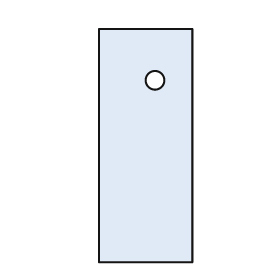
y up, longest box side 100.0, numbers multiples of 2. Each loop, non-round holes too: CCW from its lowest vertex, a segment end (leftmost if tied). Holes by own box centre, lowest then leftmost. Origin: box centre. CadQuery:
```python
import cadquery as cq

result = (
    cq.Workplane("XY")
    .moveTo(-20.0, -50.0)
    .lineTo(20.0, -50.0)
    .lineTo(20.0, 50.0)
    .lineTo(-20.0, 50.0)
    .close()
    .moveTo(4.0, 28.0)
    .circle(4.0)
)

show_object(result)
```